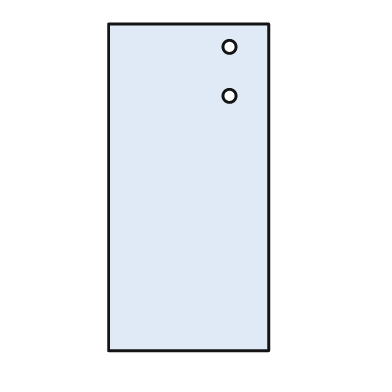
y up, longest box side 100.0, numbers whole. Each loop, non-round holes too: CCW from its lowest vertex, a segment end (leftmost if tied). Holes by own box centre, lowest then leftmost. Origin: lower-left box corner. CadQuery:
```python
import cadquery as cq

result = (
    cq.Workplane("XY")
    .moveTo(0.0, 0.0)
    .lineTo(49.0, 0.0)
    .lineTo(49.0, 100.0)
    .lineTo(0.0, 100.0)
    .close()
    .moveTo(37.0, 78.0)
    .circle(2.0)
    .moveTo(37.0, 93.0)
    .circle(2.0)
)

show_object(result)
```